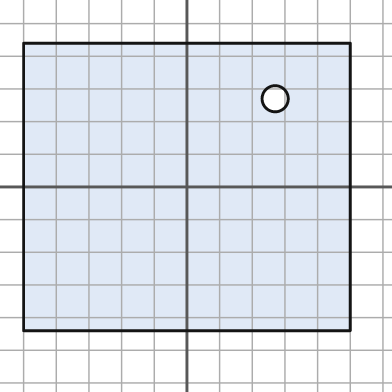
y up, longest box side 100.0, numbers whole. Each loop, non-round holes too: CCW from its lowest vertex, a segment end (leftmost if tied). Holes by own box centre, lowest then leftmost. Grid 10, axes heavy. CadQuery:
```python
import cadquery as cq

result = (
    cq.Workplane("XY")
    .moveTo(-50.0, -44.0)
    .lineTo(50.0, -44.0)
    .lineTo(50.0, 44.0)
    .lineTo(-50.0, 44.0)
    .close()
    .moveTo(27.0, 27.0)
    .circle(4.0)
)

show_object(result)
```